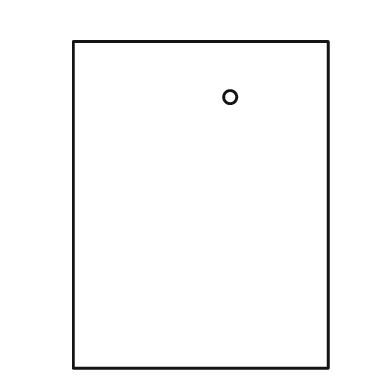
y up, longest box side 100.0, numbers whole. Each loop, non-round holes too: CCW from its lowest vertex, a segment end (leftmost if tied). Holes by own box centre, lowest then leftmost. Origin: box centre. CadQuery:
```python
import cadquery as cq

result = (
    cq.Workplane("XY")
    .moveTo(-39.0, -50.0)
    .lineTo(39.0, -50.0)
    .lineTo(39.0, 50.0)
    .lineTo(-39.0, 50.0)
    .close()
    .moveTo(9.0, 33.0)
    .circle(2.0)
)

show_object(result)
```